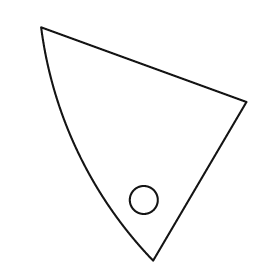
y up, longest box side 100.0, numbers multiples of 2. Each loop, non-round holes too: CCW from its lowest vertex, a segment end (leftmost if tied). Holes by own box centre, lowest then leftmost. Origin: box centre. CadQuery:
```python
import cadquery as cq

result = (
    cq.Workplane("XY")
    .moveTo(4.0, -50.0)
    .lineTo(44.0, 18.0)
    .lineTo(-44.0, 50.0)
    .threePointArc((-28.0, -4.0), (4.0, -50.0))
    .close()
    .moveTo(0.0, -24.0)
    .circle(6.0)
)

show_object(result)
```